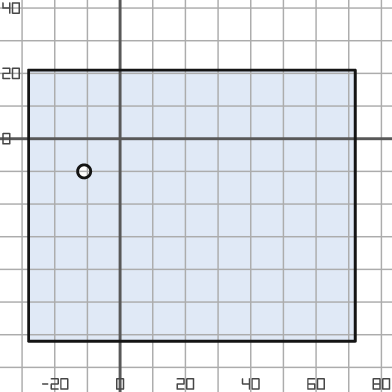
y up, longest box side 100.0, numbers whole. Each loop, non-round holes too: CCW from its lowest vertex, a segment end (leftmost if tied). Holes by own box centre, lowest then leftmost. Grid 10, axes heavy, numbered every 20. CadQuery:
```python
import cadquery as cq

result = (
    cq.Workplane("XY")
    .moveTo(-28.0, -62.0)
    .lineTo(72.0, -62.0)
    .lineTo(72.0, 21.0)
    .lineTo(-28.0, 21.0)
    .close()
    .moveTo(-11.0, -10.0)
    .circle(2.0)
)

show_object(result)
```